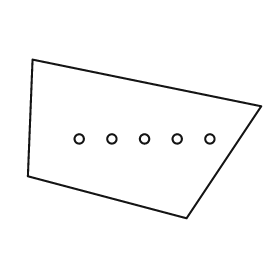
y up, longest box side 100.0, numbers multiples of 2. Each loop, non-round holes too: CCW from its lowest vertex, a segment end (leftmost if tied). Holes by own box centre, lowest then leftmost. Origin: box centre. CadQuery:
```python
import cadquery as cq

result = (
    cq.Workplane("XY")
    .moveTo(18.0, -34.0)
    .lineTo(50.0, 14.0)
    .lineTo(-48.0, 34.0)
    .lineTo(-50.0, -16.0)
    .close()
    .moveTo(-28.0, 0.0)
    .circle(2.0)
    .moveTo(-14.0, 0.0)
    .circle(2.0)
    .moveTo(0.0, 0.0)
    .circle(2.0)
    .moveTo(14.0, 0.0)
    .circle(2.0)
    .moveTo(28.0, 0.0)
    .circle(2.0)
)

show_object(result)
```